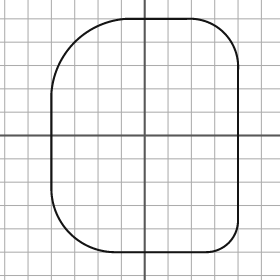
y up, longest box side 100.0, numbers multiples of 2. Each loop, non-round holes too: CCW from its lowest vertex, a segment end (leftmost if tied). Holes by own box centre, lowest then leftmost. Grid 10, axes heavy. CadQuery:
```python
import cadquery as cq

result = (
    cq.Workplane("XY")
    .moveTo(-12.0, -50.0)
    .lineTo(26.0, -50.0)
    .threePointArc((36.0, -46.0), (40.0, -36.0))
    .lineTo(40.0, 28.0)
    .threePointArc((34.0, 44.0), (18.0, 50.0))
    .lineTo(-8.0, 50.0)
    .threePointArc((-30.0, 40.0), (-40.0, 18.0))
    .lineTo(-40.0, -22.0)
    .threePointArc((-32.0, -42.0), (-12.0, -50.0))
    .close()
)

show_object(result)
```